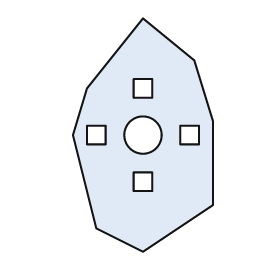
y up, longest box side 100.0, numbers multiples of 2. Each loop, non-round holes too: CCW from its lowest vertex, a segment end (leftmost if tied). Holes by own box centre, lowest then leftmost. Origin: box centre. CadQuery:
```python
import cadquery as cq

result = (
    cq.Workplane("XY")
    .moveTo(0.0, -50.0)
    .lineTo(30.0, -30.0)
    .lineTo(30.0, 6.0)
    .lineTo(22.0, 32.0)
    .lineTo(0.0, 50.0)
    .lineTo(-24.0, 20.0)
    .lineTo(-30.0, 0.0)
    .lineTo(-20.0, -40.0)
    .close()
    .moveTo(-4.0, -24.0)
    .lineTo(4.0, -24.0)
    .lineTo(4.0, -16.0)
    .lineTo(-4.0, -16.0)
    .close()
    .moveTo(-24.0, -4.0)
    .lineTo(-16.0, -4.0)
    .lineTo(-16.0, 4.0)
    .lineTo(-24.0, 4.0)
    .close()
    .moveTo(0.0, 0.0)
    .circle(8.0)
    .moveTo(16.0, -4.0)
    .lineTo(24.0, -4.0)
    .lineTo(24.0, 4.0)
    .lineTo(16.0, 4.0)
    .close()
    .moveTo(-4.0, 16.0)
    .lineTo(4.0, 16.0)
    .lineTo(4.0, 24.0)
    .lineTo(-4.0, 24.0)
    .close()
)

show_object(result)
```